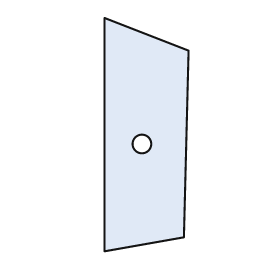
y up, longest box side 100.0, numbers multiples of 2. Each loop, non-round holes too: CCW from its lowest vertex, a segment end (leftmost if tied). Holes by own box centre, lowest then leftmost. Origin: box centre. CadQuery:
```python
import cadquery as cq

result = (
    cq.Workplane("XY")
    .moveTo(-18.0, -50.0)
    .lineTo(16.0, -44.0)
    .lineTo(18.0, 36.0)
    .lineTo(-18.0, 50.0)
    .close()
    .moveTo(-2.0, -4.0)
    .circle(4.0)
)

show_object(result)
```